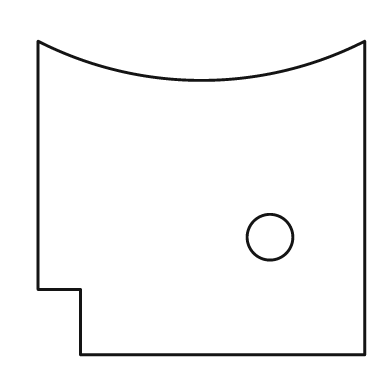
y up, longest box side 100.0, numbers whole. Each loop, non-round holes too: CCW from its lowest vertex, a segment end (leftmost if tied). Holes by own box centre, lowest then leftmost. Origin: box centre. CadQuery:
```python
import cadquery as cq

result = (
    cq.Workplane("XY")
    .moveTo(-37.0, -48.0)
    .lineTo(50.0, -48.0)
    .lineTo(50.0, 48.0)
    .threePointArc((0.0, 36.0), (-50.0, 48.0))
    .lineTo(-50.0, -28.0)
    .lineTo(-37.0, -28.0)
    .close()
    .moveTo(21.0, -12.0)
    .circle(7.0)
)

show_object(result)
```